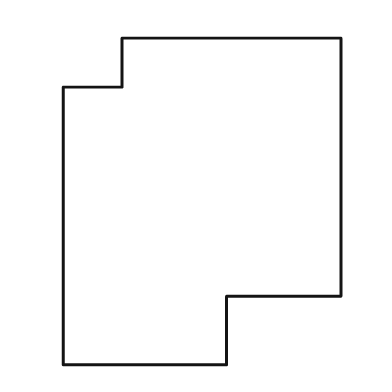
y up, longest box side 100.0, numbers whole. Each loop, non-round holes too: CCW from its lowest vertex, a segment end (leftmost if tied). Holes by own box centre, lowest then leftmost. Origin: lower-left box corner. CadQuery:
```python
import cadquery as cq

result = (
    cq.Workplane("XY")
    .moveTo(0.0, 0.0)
    .lineTo(50.0, 0.0)
    .lineTo(50.0, 21.0)
    .lineTo(85.0, 21.0)
    .lineTo(85.0, 100.0)
    .lineTo(18.0, 100.0)
    .lineTo(18.0, 85.0)
    .lineTo(0.0, 85.0)
    .close()
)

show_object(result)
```